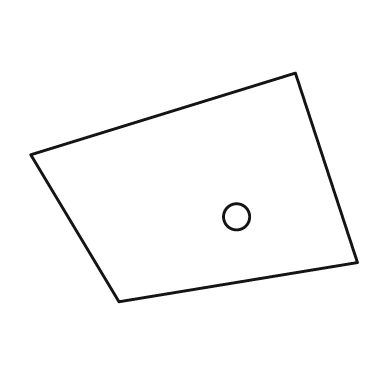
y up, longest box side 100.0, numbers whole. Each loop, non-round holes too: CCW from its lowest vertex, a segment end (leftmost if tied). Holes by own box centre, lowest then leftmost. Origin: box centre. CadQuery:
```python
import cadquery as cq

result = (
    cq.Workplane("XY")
    .moveTo(-23.0, -35.0)
    .lineTo(50.0, -23.0)
    .lineTo(31.0, 35.0)
    .lineTo(-50.0, 10.0)
    .close()
    .moveTo(13.0, -9.0)
    .circle(4.0)
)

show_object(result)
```